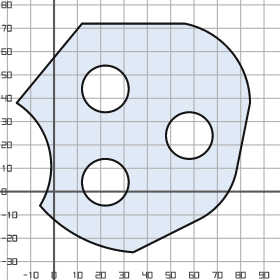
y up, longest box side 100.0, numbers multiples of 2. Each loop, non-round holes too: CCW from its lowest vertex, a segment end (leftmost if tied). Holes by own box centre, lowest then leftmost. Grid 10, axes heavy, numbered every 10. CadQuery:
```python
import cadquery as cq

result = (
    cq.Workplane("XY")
    .moveTo(34.0, -26.0)
    .lineTo(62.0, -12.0)
    .threePointArc((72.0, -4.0), (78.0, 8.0))
    .lineTo(84.0, 38.0)
    .threePointArc((76.0, 60.0), (56.0, 72.0))
    .lineTo(12.0, 72.0)
    .lineTo(-16.0, 38.0)
    .threePointArc((-2.0, 18.0), (-6.0, -6.0))
    .threePointArc((12.0, -20.0), (34.0, -26.0))
    .close()
    .moveTo(22.0, 4.0)
    .circle(10.0)
    .moveTo(58.0, 24.0)
    .circle(10.0)
    .moveTo(22.0, 44.0)
    .circle(10.0)
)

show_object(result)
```